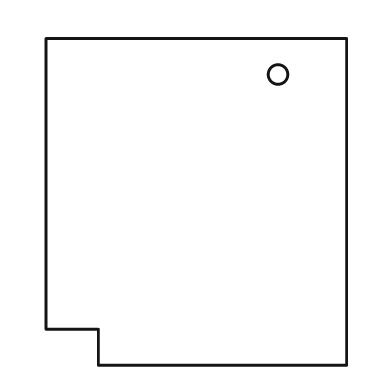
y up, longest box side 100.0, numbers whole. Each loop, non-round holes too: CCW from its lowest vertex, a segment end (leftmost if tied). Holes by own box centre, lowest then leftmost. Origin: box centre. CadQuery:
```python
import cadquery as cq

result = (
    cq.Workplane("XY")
    .moveTo(-30.0, -50.0)
    .lineTo(46.0, -50.0)
    .lineTo(46.0, 50.0)
    .lineTo(-46.0, 50.0)
    .lineTo(-46.0, -39.0)
    .lineTo(-30.0, -39.0)
    .close()
    .moveTo(25.0, 39.0)
    .circle(3.0)
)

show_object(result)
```